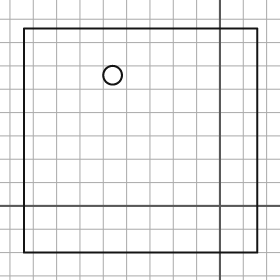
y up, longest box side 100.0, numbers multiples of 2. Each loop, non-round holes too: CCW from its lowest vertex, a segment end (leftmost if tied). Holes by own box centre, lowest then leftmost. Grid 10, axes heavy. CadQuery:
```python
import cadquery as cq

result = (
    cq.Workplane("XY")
    .moveTo(-84.0, -20.0)
    .lineTo(16.0, -20.0)
    .lineTo(16.0, 76.0)
    .lineTo(-84.0, 76.0)
    .close()
    .moveTo(-46.0, 56.0)
    .circle(4.0)
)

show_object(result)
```